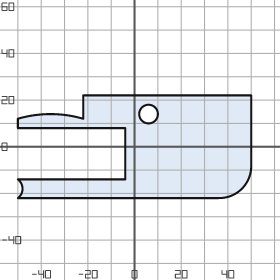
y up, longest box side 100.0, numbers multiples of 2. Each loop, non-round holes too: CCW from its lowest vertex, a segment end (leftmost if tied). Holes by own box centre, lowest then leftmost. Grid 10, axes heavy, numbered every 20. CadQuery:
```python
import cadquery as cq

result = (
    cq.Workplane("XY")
    .moveTo(-50.0, -22.0)
    .lineTo(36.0, -22.0)
    .threePointArc((46.0, -18.0), (50.0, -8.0))
    .lineTo(50.0, 22.0)
    .lineTo(-22.0, 22.0)
    .lineTo(-22.0, 12.0)
    .threePointArc((-36.0, 14.0), (-50.0, 12.0))
    .lineTo(-50.0, 8.0)
    .lineTo(-4.0, 8.0)
    .lineTo(-4.0, -14.0)
    .lineTo(-50.0, -14.0)
    .threePointArc((-48.0, -18.0), (-50.0, -22.0))
    .close()
    .moveTo(6.0, 14.0)
    .circle(4.0)
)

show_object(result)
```